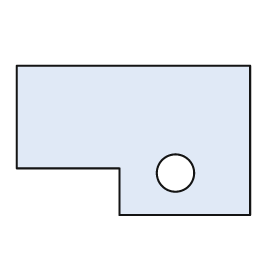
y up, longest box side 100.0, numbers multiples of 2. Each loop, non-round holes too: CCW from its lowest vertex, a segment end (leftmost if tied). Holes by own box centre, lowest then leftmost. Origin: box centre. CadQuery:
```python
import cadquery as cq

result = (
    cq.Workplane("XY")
    .moveTo(-6.0, -32.0)
    .lineTo(50.0, -32.0)
    .lineTo(50.0, 32.0)
    .lineTo(-50.0, 32.0)
    .lineTo(-50.0, -12.0)
    .lineTo(-6.0, -12.0)
    .close()
    .moveTo(18.0, -14.0)
    .circle(8.0)
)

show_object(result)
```